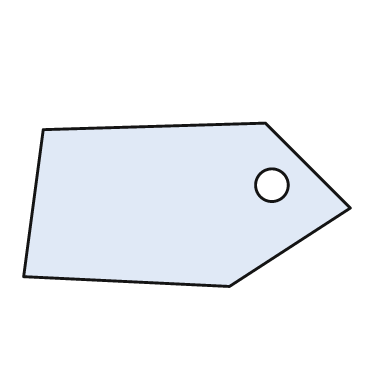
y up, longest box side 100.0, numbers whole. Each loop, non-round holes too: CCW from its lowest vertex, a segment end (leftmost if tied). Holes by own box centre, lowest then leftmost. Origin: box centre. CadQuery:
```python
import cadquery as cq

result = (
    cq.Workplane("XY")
    .moveTo(13.0, -25.0)
    .lineTo(50.0, -1.0)
    .lineTo(24.0, 25.0)
    .lineTo(-44.0, 23.0)
    .lineTo(-50.0, -22.0)
    .close()
    .moveTo(26.0, 6.0)
    .circle(5.0)
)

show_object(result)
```